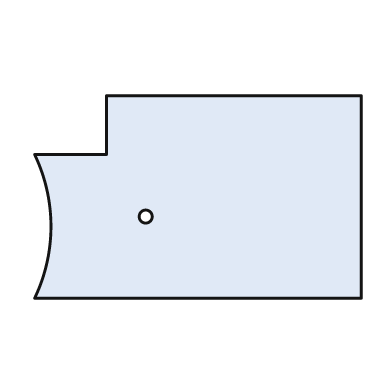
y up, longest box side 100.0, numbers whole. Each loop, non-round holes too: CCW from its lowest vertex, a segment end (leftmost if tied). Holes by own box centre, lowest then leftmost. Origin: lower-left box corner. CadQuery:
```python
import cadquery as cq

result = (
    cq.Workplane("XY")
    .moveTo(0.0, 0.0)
    .lineTo(100.0, 0.0)
    .lineTo(100.0, 62.0)
    .lineTo(22.0, 62.0)
    .lineTo(22.0, 44.0)
    .lineTo(0.0, 44.0)
    .threePointArc((5.0, 22.0), (0.0, 0.0))
    .close()
    .moveTo(34.0, 25.0)
    .circle(2.0)
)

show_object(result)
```